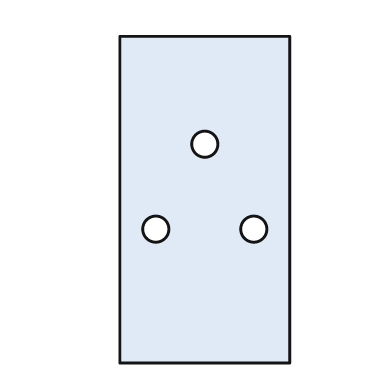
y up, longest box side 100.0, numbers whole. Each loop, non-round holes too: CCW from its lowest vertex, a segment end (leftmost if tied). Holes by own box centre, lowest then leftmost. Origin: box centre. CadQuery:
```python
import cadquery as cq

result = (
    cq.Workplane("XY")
    .moveTo(-26.0, -50.0)
    .lineTo(26.0, -50.0)
    .lineTo(26.0, 50.0)
    .lineTo(-26.0, 50.0)
    .close()
    .moveTo(-15.0, -9.0)
    .circle(4.0)
    .moveTo(15.0, -9.0)
    .circle(4.0)
    .moveTo(0.0, 17.0)
    .circle(4.0)
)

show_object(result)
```